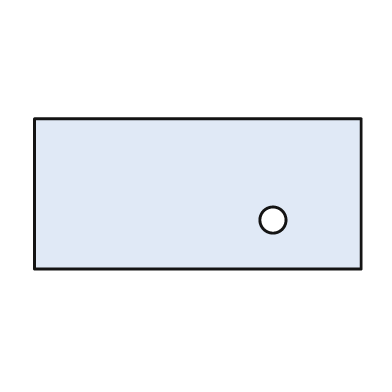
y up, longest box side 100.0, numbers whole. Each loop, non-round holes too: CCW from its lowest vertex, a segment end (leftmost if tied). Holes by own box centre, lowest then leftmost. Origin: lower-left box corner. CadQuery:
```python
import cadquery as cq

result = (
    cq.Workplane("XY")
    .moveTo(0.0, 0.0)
    .lineTo(100.0, 0.0)
    .lineTo(100.0, 46.0)
    .lineTo(0.0, 46.0)
    .close()
    .moveTo(73.0, 15.0)
    .circle(4.0)
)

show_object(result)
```